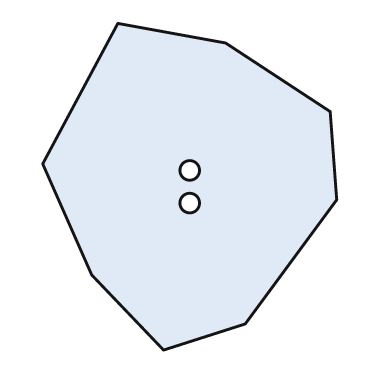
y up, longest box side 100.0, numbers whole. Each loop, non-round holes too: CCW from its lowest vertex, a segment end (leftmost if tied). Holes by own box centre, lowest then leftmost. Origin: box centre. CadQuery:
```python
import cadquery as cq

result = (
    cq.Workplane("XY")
    .moveTo(-8.0, -50.0)
    .lineTo(17.0, -42.0)
    .lineTo(45.0, -4.0)
    .lineTo(43.0, 23.0)
    .lineTo(11.0, 44.0)
    .lineTo(-22.0, 50.0)
    .lineTo(-45.0, 7.0)
    .lineTo(-30.0, -27.0)
    .close()
    .moveTo(0.0, -5.0)
    .circle(3.0)
    .moveTo(0.0, 5.0)
    .circle(3.0)
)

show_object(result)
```